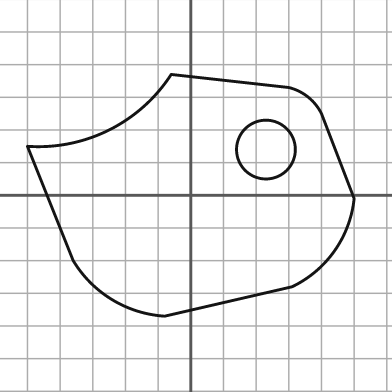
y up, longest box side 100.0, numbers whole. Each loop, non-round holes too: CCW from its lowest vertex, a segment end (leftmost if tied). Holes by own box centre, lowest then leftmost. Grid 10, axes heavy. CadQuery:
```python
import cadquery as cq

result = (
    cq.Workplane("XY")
    .moveTo(-8.0, -37.0)
    .lineTo(31.0, -28.0)
    .threePointArc((44.0, -17.0), (50.0, -1.0))
    .lineTo(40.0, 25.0)
    .threePointArc((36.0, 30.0), (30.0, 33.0))
    .lineTo(-6.0, 37.0)
    .threePointArc((-25.0, 20.0), (-50.0, 15.0))
    .lineTo(-36.0, -20.0)
    .threePointArc((-24.0, -32.0), (-8.0, -37.0))
    .close()
    .moveTo(23.0, 14.0)
    .circle(9.0)
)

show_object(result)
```